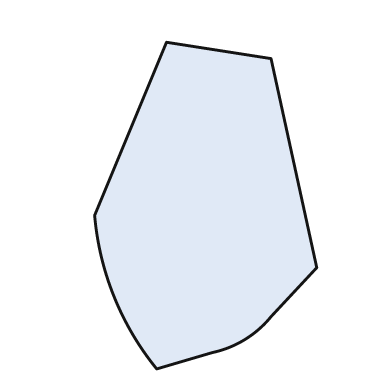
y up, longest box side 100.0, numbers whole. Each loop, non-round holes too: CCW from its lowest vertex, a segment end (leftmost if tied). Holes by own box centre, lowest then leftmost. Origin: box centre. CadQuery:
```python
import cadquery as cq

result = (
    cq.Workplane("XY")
    .moveTo(-15.0, -50.0)
    .lineTo(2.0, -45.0)
    .threePointArc((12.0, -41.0), (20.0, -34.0))
    .lineTo(34.0, -19.0)
    .lineTo(20.0, 45.0)
    .lineTo(-12.0, 50.0)
    .lineTo(-34.0, -3.0)
    .threePointArc((-28.0, -28.0), (-15.0, -50.0))
    .close()
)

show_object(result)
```